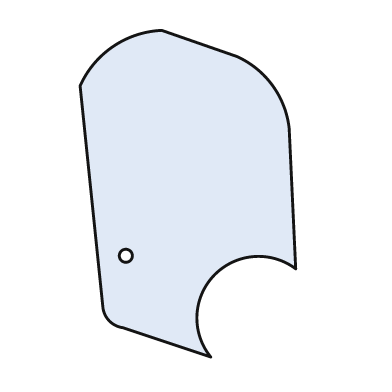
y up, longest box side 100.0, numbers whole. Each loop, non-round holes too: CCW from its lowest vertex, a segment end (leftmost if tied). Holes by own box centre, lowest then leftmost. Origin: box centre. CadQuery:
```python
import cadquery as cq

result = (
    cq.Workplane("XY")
    .moveTo(7.0, -50.0)
    .threePointArc((8.0, -25.0), (33.0, -23.0))
    .lineTo(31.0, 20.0)
    .threePointArc((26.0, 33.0), (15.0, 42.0))
    .lineTo(-8.0, 50.0)
    .threePointArc((-23.0, 45.0), (-33.0, 33.0))
    .lineTo(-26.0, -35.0)
    .threePointArc((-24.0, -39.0), (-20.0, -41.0))
    .close()
    .moveTo(-19.0, -19.0)
    .circle(2.0)
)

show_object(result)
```